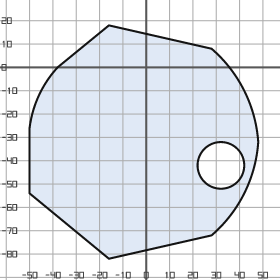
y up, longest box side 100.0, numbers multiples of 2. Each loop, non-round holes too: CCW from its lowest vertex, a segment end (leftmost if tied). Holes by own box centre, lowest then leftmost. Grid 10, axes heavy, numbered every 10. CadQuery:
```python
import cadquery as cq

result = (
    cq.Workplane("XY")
    .moveTo(-16.0, -82.0)
    .lineTo(28.0, -72.0)
    .threePointArc((42.0, -54.0), (48.0, -32.0))
    .threePointArc((42.0, -10.0), (28.0, 8.0))
    .lineTo(-16.0, 18.0)
    .lineTo(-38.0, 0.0)
    .threePointArc((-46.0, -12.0), (-50.0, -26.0))
    .lineTo(-50.0, -54.0)
    .close()
    .moveTo(32.0, -42.0)
    .circle(10.0)
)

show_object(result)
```